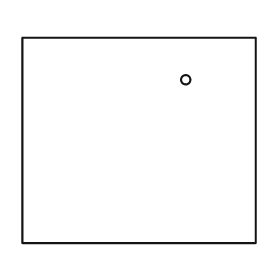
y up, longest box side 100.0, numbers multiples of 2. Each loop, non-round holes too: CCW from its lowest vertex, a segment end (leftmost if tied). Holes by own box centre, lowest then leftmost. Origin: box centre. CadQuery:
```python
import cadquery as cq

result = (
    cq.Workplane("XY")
    .moveTo(-50.0, -44.0)
    .lineTo(50.0, -44.0)
    .lineTo(50.0, 44.0)
    .lineTo(-50.0, 44.0)
    .close()
    .moveTo(20.0, 26.0)
    .circle(2.0)
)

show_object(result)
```